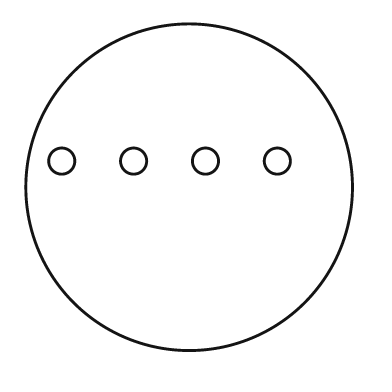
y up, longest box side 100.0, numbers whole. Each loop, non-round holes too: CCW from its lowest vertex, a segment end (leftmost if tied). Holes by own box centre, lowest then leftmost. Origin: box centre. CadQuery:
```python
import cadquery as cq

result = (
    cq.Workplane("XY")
    .moveTo(0.0, 0.0)
    .circle(50.0)
    .moveTo(-39.0, 8.0)
    .circle(4.0)
    .moveTo(-17.0, 8.0)
    .circle(4.0)
    .moveTo(5.0, 8.0)
    .circle(4.0)
    .moveTo(27.0, 8.0)
    .circle(4.0)
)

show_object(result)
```